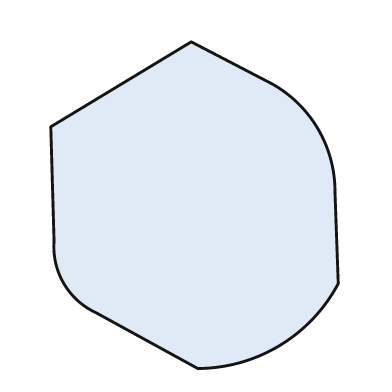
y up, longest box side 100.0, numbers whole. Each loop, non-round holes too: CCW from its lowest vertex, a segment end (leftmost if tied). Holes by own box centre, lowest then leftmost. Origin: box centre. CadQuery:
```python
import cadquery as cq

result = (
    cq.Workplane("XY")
    .moveTo(1.0, -50.0)
    .threePointArc((26.0, -43.0), (44.0, -24.0))
    .lineTo(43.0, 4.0)
    .threePointArc((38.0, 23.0), (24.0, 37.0))
    .lineTo(-1.0, 50.0)
    .lineTo(-44.0, 24.0)
    .lineTo(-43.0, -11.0)
    .threePointArc((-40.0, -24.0), (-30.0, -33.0))
    .close()
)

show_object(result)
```